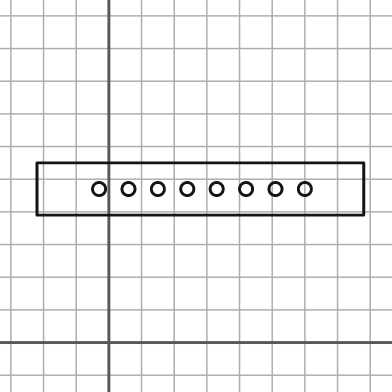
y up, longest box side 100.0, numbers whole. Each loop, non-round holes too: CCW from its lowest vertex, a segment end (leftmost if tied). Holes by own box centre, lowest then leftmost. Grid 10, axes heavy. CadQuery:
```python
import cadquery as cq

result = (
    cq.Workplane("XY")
    .moveTo(-22.0, 39.0)
    .lineTo(78.0, 39.0)
    .lineTo(78.0, 55.0)
    .lineTo(-22.0, 55.0)
    .close()
    .moveTo(-3.0, 47.0)
    .circle(2.0)
    .moveTo(6.0, 47.0)
    .circle(2.0)
    .moveTo(15.0, 47.0)
    .circle(2.0)
    .moveTo(24.0, 47.0)
    .circle(2.0)
    .moveTo(33.0, 47.0)
    .circle(2.0)
    .moveTo(42.0, 47.0)
    .circle(2.0)
    .moveTo(51.0, 47.0)
    .circle(2.0)
    .moveTo(60.0, 47.0)
    .circle(2.0)
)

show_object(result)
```